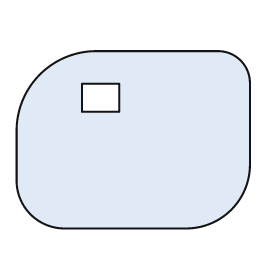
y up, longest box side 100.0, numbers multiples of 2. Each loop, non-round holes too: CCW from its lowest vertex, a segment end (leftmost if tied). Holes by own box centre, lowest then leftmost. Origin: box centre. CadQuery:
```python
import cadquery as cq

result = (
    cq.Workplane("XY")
    .moveTo(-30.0, -38.0)
    .lineTo(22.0, -38.0)
    .threePointArc((42.0, -30.0), (50.0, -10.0))
    .lineTo(50.0, 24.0)
    .threePointArc((46.0, 34.0), (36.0, 38.0))
    .lineTo(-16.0, 38.0)
    .threePointArc((-40.0, 28.0), (-50.0, 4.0))
    .lineTo(-50.0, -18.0)
    .threePointArc((-44.0, -32.0), (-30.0, -38.0))
    .close()
    .moveTo(-22.0, 12.0)
    .lineTo(-6.0, 12.0)
    .lineTo(-6.0, 24.0)
    .lineTo(-22.0, 24.0)
    .close()
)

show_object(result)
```